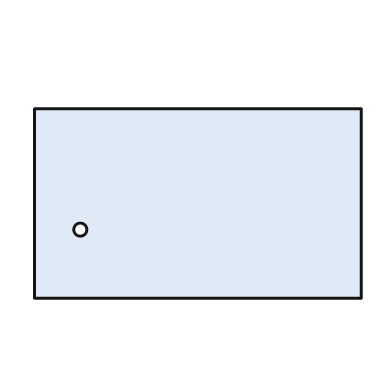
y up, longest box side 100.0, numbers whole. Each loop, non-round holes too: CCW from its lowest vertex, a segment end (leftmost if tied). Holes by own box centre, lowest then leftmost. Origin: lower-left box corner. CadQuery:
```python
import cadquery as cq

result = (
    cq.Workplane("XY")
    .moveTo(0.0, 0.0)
    .lineTo(100.0, 0.0)
    .lineTo(100.0, 58.0)
    .lineTo(0.0, 58.0)
    .close()
    .moveTo(14.0, 21.0)
    .circle(2.0)
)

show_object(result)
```